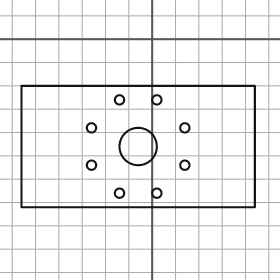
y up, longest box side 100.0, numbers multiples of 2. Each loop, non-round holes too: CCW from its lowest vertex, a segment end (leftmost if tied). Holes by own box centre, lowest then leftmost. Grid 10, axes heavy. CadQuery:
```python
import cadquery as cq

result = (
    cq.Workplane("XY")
    .moveTo(-56.0, -72.0)
    .lineTo(44.0, -72.0)
    .lineTo(44.0, -20.0)
    .lineTo(-56.0, -20.0)
    .close()
    .moveTo(-14.0, -66.0)
    .circle(2.0)
    .moveTo(2.0, -66.0)
    .circle(2.0)
    .moveTo(-26.0, -54.0)
    .circle(2.0)
    .moveTo(14.0, -54.0)
    .circle(2.0)
    .moveTo(-6.0, -46.0)
    .circle(8.0)
    .moveTo(-26.0, -38.0)
    .circle(2.0)
    .moveTo(14.0, -38.0)
    .circle(2.0)
    .moveTo(-14.0, -26.0)
    .circle(2.0)
    .moveTo(2.0, -26.0)
    .circle(2.0)
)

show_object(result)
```